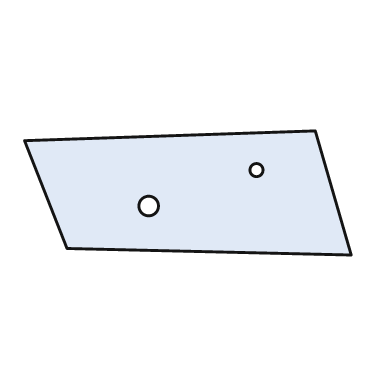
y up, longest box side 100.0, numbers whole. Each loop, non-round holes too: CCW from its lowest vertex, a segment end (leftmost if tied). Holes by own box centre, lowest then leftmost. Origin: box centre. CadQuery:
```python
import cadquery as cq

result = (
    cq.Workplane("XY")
    .moveTo(50.0, -19.0)
    .lineTo(39.0, 19.0)
    .lineTo(-50.0, 16.0)
    .lineTo(-37.0, -17.0)
    .close()
    .moveTo(-12.0, -4.0)
    .circle(3.0)
    .moveTo(21.0, 7.0)
    .circle(2.0)
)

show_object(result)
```